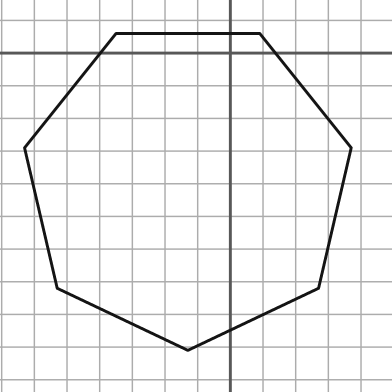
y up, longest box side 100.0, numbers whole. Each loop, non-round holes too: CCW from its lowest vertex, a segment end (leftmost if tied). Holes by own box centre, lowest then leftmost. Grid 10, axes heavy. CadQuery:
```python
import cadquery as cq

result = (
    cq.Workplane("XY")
    .moveTo(-13.0, -91.0)
    .lineTo(27.0, -72.0)
    .lineTo(37.0, -29.0)
    .lineTo(9.0, 6.0)
    .lineTo(-35.0, 6.0)
    .lineTo(-63.0, -29.0)
    .lineTo(-53.0, -72.0)
    .close()
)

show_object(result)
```